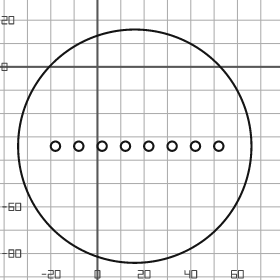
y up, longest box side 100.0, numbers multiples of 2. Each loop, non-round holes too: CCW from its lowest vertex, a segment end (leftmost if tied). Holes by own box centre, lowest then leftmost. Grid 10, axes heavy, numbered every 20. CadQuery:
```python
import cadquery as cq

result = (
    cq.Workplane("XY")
    .moveTo(16.0, -34.0)
    .circle(50.0)
    .moveTo(-18.0, -34.0)
    .circle(2.0)
    .moveTo(-8.0, -34.0)
    .circle(2.0)
    .moveTo(2.0, -34.0)
    .circle(2.0)
    .moveTo(12.0, -34.0)
    .circle(2.0)
    .moveTo(22.0, -34.0)
    .circle(2.0)
    .moveTo(32.0, -34.0)
    .circle(2.0)
    .moveTo(42.0, -34.0)
    .circle(2.0)
    .moveTo(52.0, -34.0)
    .circle(2.0)
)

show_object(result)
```